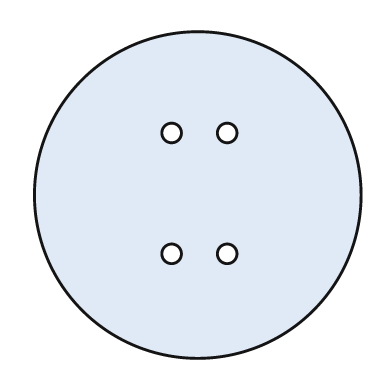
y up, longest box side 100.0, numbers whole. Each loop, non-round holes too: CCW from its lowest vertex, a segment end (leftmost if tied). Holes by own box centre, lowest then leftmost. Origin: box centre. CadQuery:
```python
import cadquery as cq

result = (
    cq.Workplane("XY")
    .moveTo(0.0, 0.0)
    .circle(50.0)
    .moveTo(-8.0, -18.0)
    .circle(3.0)
    .moveTo(9.0, -18.0)
    .circle(3.0)
    .moveTo(-8.0, 19.0)
    .circle(3.0)
    .moveTo(9.0, 19.0)
    .circle(3.0)
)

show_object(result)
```